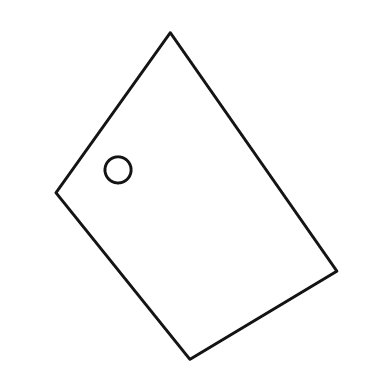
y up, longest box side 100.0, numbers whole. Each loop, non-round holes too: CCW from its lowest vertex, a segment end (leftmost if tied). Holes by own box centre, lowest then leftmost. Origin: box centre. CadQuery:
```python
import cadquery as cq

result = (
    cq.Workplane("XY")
    .moveTo(-2.0, -50.0)
    .lineTo(43.0, -23.0)
    .lineTo(-8.0, 50.0)
    .lineTo(-43.0, 1.0)
    .close()
    .moveTo(-24.0, 8.0)
    .circle(4.0)
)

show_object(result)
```